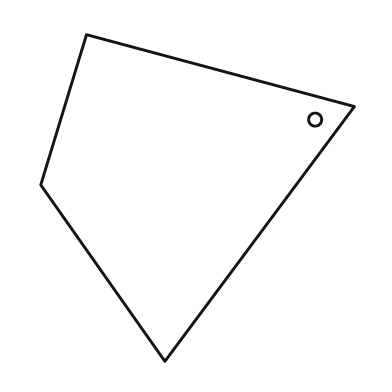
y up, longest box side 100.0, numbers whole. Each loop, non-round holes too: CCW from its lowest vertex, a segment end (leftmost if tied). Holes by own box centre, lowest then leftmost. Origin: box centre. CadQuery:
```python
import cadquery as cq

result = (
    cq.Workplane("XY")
    .moveTo(-10.0, -50.0)
    .lineTo(48.0, 28.0)
    .lineTo(-34.0, 50.0)
    .lineTo(-48.0, 4.0)
    .close()
    .moveTo(36.0, 24.0)
    .circle(2.0)
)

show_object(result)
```